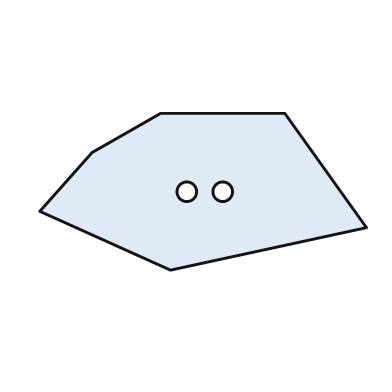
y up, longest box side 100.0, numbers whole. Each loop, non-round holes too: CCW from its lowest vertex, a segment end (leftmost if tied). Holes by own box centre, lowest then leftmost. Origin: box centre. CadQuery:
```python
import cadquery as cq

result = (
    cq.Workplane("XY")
    .moveTo(-10.0, -24.0)
    .lineTo(50.0, -11.0)
    .lineTo(25.0, 24.0)
    .lineTo(-13.0, 24.0)
    .lineTo(-34.0, 12.0)
    .lineTo(-50.0, -6.0)
    .close()
    .moveTo(-5.0, 0.0)
    .circle(3.0)
    .moveTo(6.0, 0.0)
    .circle(3.0)
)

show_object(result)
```